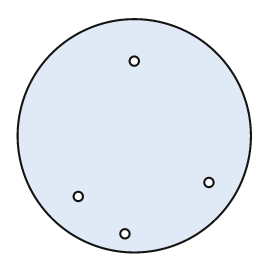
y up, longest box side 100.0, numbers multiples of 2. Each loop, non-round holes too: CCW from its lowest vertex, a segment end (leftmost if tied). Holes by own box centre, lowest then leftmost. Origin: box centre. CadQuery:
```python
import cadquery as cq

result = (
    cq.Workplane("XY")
    .moveTo(0.0, 0.0)
    .circle(50.0)
    .moveTo(-4.0, -42.0)
    .circle(2.0)
    .moveTo(-24.0, -26.0)
    .circle(2.0)
    .moveTo(32.0, -20.0)
    .circle(2.0)
    .moveTo(0.0, 32.0)
    .circle(2.0)
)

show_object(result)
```